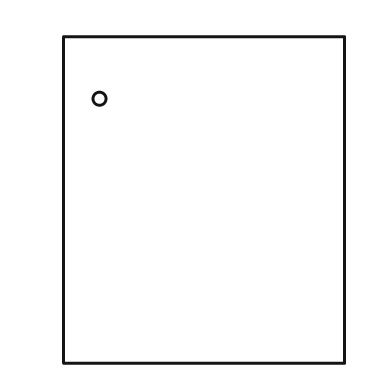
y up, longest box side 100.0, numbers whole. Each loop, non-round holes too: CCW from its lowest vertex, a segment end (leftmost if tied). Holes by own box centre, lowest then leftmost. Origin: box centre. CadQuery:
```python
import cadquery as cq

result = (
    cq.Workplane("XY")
    .moveTo(-43.0, -50.0)
    .lineTo(43.0, -50.0)
    .lineTo(43.0, 50.0)
    .lineTo(-43.0, 50.0)
    .close()
    .moveTo(-32.0, 31.0)
    .circle(2.0)
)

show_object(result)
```